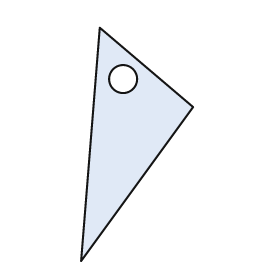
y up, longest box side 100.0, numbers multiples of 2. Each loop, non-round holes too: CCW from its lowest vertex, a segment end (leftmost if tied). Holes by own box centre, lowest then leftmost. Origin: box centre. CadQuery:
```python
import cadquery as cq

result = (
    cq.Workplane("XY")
    .moveTo(-24.0, -50.0)
    .lineTo(24.0, 16.0)
    .lineTo(-16.0, 50.0)
    .close()
    .moveTo(-6.0, 28.0)
    .circle(6.0)
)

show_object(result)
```